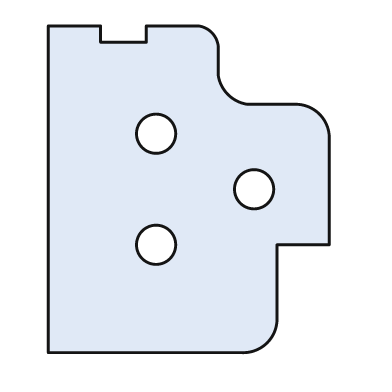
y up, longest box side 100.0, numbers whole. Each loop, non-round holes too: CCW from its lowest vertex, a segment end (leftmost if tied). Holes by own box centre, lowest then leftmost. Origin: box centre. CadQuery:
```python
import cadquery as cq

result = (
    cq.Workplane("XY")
    .moveTo(-43.0, -50.0)
    .lineTo(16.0, -50.0)
    .threePointArc((24.0, -47.0), (27.0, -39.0))
    .lineTo(27.0, -17.0)
    .lineTo(43.0, -17.0)
    .lineTo(43.0, 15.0)
    .threePointArc((40.0, 23.0), (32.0, 26.0))
    .lineTo(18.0, 26.0)
    .threePointArc((12.0, 29.0), (9.0, 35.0))
    .lineTo(9.0, 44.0)
    .threePointArc((7.0, 48.0), (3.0, 50.0))
    .lineTo(-13.0, 50.0)
    .lineTo(-13.0, 45.0)
    .lineTo(-27.0, 45.0)
    .lineTo(-27.0, 50.0)
    .lineTo(-43.0, 50.0)
    .close()
    .moveTo(-10.0, -17.0)
    .circle(6.0)
    .moveTo(20.0, 0.0)
    .circle(6.0)
    .moveTo(-10.0, 17.0)
    .circle(6.0)
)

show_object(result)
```